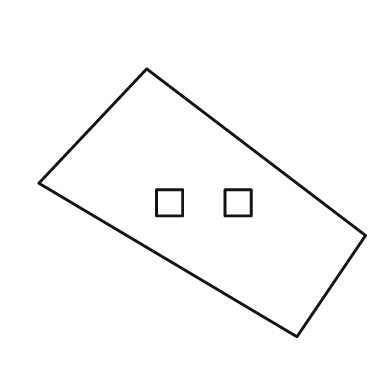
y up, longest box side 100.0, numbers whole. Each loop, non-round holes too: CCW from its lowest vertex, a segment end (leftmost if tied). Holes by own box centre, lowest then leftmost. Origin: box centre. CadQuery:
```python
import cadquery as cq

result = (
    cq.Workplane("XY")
    .moveTo(29.0, -41.0)
    .lineTo(50.0, -10.0)
    .lineTo(-17.0, 41.0)
    .lineTo(-50.0, 6.0)
    .close()
    .moveTo(-14.0, -4.0)
    .lineTo(-6.0, -4.0)
    .lineTo(-6.0, 4.0)
    .lineTo(-14.0, 4.0)
    .close()
    .moveTo(7.0, -4.0)
    .lineTo(15.0, -4.0)
    .lineTo(15.0, 4.0)
    .lineTo(7.0, 4.0)
    .close()
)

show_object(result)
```